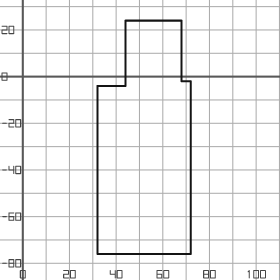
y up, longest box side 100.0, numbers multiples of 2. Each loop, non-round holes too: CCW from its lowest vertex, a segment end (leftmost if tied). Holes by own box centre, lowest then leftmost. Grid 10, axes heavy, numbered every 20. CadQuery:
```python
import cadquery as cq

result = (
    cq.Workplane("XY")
    .moveTo(32.0, -76.0)
    .lineTo(72.0, -76.0)
    .lineTo(72.0, -2.0)
    .lineTo(68.0, -2.0)
    .lineTo(68.0, 24.0)
    .lineTo(44.0, 24.0)
    .lineTo(44.0, -4.0)
    .lineTo(32.0, -4.0)
    .close()
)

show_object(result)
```